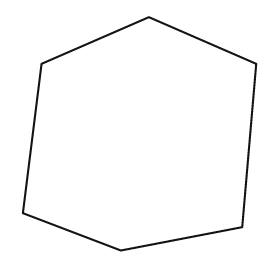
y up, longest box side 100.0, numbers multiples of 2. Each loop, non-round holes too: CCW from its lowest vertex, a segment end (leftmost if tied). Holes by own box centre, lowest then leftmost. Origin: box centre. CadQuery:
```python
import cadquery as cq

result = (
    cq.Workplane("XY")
    .moveTo(-8.0, -50.0)
    .lineTo(44.0, -40.0)
    .lineTo(50.0, 30.0)
    .lineTo(4.0, 50.0)
    .lineTo(-42.0, 30.0)
    .lineTo(-50.0, -34.0)
    .close()
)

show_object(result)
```